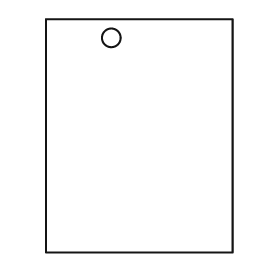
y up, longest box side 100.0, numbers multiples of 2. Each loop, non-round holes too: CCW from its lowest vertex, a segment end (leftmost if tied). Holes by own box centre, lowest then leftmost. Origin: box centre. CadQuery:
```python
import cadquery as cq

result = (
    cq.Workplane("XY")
    .moveTo(-40.0, -50.0)
    .lineTo(40.0, -50.0)
    .lineTo(40.0, 50.0)
    .lineTo(-40.0, 50.0)
    .close()
    .moveTo(-12.0, 42.0)
    .circle(4.0)
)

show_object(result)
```